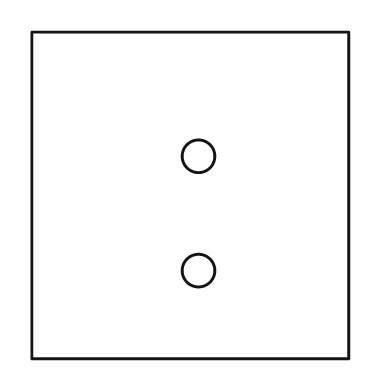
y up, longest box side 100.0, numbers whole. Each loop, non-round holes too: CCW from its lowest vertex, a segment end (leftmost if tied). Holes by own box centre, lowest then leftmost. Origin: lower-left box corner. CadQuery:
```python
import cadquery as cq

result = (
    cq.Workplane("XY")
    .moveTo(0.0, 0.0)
    .lineTo(97.0, 0.0)
    .lineTo(97.0, 100.0)
    .lineTo(0.0, 100.0)
    .close()
    .moveTo(51.0, 27.0)
    .circle(5.0)
    .moveTo(51.0, 62.0)
    .circle(5.0)
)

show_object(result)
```